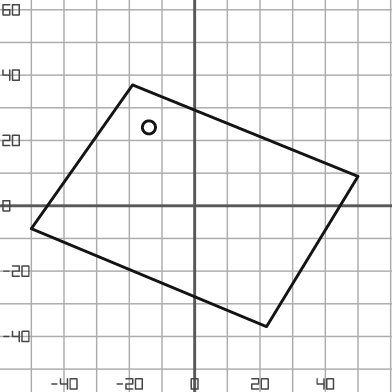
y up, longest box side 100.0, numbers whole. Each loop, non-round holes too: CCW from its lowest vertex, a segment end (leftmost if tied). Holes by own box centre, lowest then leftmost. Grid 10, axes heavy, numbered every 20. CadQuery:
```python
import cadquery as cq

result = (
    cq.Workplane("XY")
    .moveTo(22.0, -37.0)
    .lineTo(50.0, 9.0)
    .lineTo(-19.0, 37.0)
    .lineTo(-50.0, -7.0)
    .close()
    .moveTo(-14.0, 24.0)
    .circle(2.0)
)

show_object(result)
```